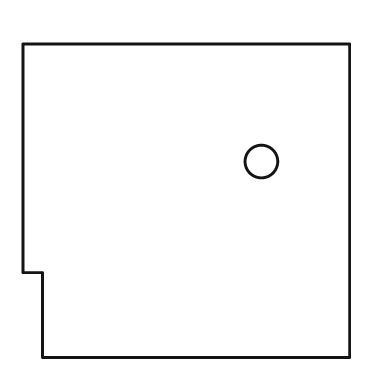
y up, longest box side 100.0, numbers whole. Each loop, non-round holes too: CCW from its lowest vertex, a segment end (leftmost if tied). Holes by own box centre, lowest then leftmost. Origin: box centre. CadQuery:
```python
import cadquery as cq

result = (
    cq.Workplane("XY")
    .moveTo(-44.0, -48.0)
    .lineTo(50.0, -48.0)
    .lineTo(50.0, 48.0)
    .lineTo(-50.0, 48.0)
    .lineTo(-50.0, -22.0)
    .lineTo(-44.0, -22.0)
    .close()
    .moveTo(23.0, 12.0)
    .circle(5.0)
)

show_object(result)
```